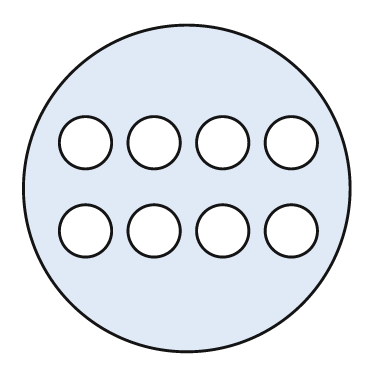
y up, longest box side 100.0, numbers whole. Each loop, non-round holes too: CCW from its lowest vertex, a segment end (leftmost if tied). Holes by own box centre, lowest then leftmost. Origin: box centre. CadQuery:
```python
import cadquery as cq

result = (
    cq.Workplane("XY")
    .moveTo(0.0, 0.0)
    .circle(50.0)
    .moveTo(-31.0, -13.0)
    .circle(8.0)
    .moveTo(-10.0, -13.0)
    .circle(8.0)
    .moveTo(11.0, -13.0)
    .circle(8.0)
    .moveTo(32.0, -13.0)
    .circle(8.0)
    .moveTo(-31.0, 14.0)
    .circle(8.0)
    .moveTo(-10.0, 14.0)
    .circle(8.0)
    .moveTo(11.0, 14.0)
    .circle(8.0)
    .moveTo(32.0, 14.0)
    .circle(8.0)
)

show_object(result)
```